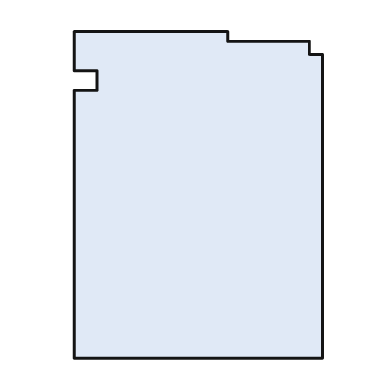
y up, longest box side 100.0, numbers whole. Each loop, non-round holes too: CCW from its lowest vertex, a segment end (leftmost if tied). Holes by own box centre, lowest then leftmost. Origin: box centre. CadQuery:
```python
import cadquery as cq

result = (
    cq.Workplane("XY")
    .moveTo(-38.0, -50.0)
    .lineTo(38.0, -50.0)
    .lineTo(38.0, 43.0)
    .lineTo(34.0, 43.0)
    .lineTo(34.0, 47.0)
    .lineTo(9.0, 47.0)
    .lineTo(9.0, 50.0)
    .lineTo(-38.0, 50.0)
    .lineTo(-38.0, 38.0)
    .lineTo(-31.0, 38.0)
    .lineTo(-31.0, 32.0)
    .lineTo(-38.0, 32.0)
    .close()
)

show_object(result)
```